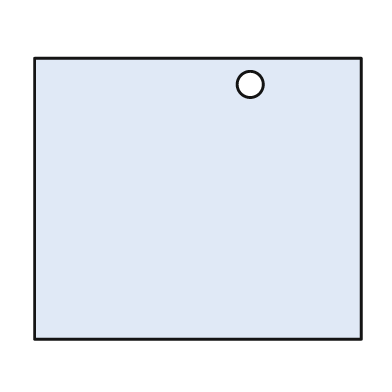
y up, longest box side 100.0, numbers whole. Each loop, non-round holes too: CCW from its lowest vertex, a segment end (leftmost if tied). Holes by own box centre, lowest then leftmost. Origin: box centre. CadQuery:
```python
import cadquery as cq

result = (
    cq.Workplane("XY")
    .moveTo(-50.0, -43.0)
    .lineTo(50.0, -43.0)
    .lineTo(50.0, 43.0)
    .lineTo(-50.0, 43.0)
    .close()
    .moveTo(16.0, 35.0)
    .circle(4.0)
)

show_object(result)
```